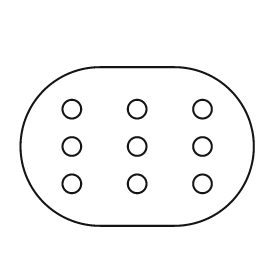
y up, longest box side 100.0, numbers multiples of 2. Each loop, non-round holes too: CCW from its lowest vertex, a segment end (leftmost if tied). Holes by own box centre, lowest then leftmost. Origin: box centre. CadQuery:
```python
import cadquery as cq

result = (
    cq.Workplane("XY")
    .moveTo(-16.0, -34.0)
    .lineTo(16.0, -34.0)
    .threePointArc((50.0, 0.0), (16.0, 34.0))
    .lineTo(-16.0, 34.0)
    .threePointArc((-50.0, 0.0), (-16.0, -34.0))
    .close()
    .moveTo(-28.0, -16.0)
    .circle(4.0)
    .moveTo(0.0, -16.0)
    .circle(4.0)
    .moveTo(28.0, -16.0)
    .circle(4.0)
    .moveTo(-28.0, 0.0)
    .circle(4.0)
    .moveTo(0.0, 0.0)
    .circle(4.0)
    .moveTo(28.0, 0.0)
    .circle(4.0)
    .moveTo(-28.0, 16.0)
    .circle(4.0)
    .moveTo(0.0, 16.0)
    .circle(4.0)
    .moveTo(28.0, 16.0)
    .circle(4.0)
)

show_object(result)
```